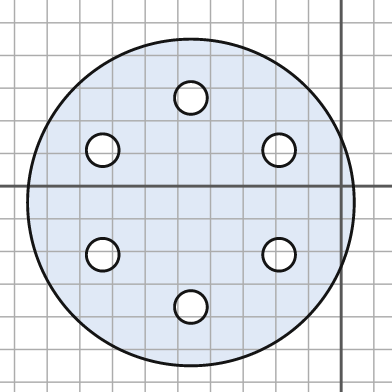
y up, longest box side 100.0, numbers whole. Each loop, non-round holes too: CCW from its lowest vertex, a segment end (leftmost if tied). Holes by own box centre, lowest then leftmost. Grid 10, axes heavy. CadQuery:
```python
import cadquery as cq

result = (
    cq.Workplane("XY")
    .moveTo(-46.0, -5.0)
    .circle(50.0)
    .moveTo(-46.0, -37.0)
    .circle(5.0)
    .moveTo(-73.0, -21.0)
    .circle(5.0)
    .moveTo(-19.0, -21.0)
    .circle(5.0)
    .moveTo(-73.0, 11.0)
    .circle(5.0)
    .moveTo(-19.0, 11.0)
    .circle(5.0)
    .moveTo(-46.0, 27.0)
    .circle(5.0)
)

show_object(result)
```